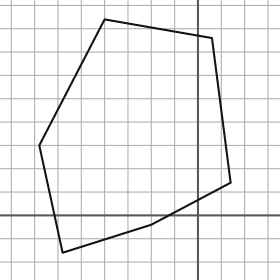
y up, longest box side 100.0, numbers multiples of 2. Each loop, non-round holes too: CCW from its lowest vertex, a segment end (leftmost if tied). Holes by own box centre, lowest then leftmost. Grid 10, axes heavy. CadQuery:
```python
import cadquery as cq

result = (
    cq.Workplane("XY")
    .moveTo(-58.0, -16.0)
    .lineTo(-20.0, -4.0)
    .lineTo(14.0, 14.0)
    .lineTo(6.0, 76.0)
    .lineTo(-40.0, 84.0)
    .lineTo(-68.0, 30.0)
    .close()
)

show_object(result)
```